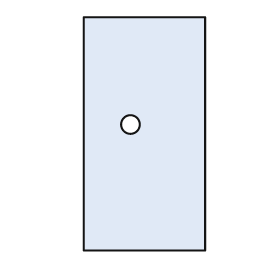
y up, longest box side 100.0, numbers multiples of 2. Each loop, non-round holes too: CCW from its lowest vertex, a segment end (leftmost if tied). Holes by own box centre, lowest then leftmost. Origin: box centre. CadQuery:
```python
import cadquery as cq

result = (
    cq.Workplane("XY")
    .moveTo(-26.0, -50.0)
    .lineTo(26.0, -50.0)
    .lineTo(26.0, 50.0)
    .lineTo(-26.0, 50.0)
    .close()
    .moveTo(-6.0, 4.0)
    .circle(4.0)
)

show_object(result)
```